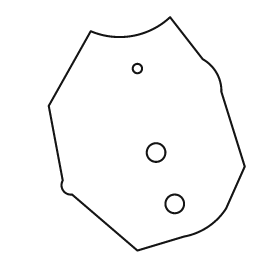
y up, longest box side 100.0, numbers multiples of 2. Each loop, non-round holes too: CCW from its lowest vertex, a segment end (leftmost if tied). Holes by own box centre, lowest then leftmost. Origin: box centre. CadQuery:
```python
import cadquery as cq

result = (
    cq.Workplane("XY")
    .moveTo(-4.0, -50.0)
    .lineTo(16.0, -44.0)
    .threePointArc((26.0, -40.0), (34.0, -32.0))
    .lineTo(42.0, -14.0)
    .lineTo(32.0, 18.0)
    .threePointArc((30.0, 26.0), (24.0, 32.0))
    .lineTo(10.0, 50.0)
    .threePointArc((-6.0, 42.0), (-24.0, 44.0))
    .lineTo(-42.0, 12.0)
    .lineTo(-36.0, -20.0)
    .threePointArc((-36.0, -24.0), (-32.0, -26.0))
    .close()
    .moveTo(12.0, -30.0)
    .circle(4.0)
    .moveTo(4.0, -8.0)
    .circle(4.0)
    .moveTo(-4.0, 28.0)
    .circle(2.0)
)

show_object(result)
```